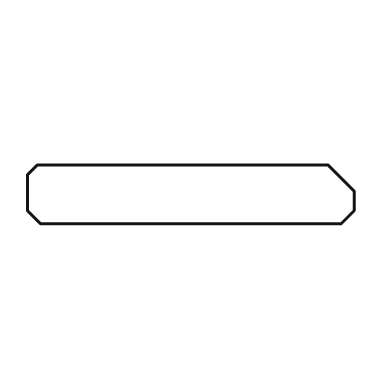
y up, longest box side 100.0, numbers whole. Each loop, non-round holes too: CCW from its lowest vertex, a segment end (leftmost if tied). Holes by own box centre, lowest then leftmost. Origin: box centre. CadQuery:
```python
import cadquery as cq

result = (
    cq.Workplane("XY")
    .moveTo(-46.0, -9.0)
    .lineTo(46.0, -9.0)
    .lineTo(50.0, -5.0)
    .lineTo(50.0, 1.0)
    .lineTo(42.0, 9.0)
    .lineTo(-47.0, 9.0)
    .lineTo(-50.0, 6.0)
    .lineTo(-50.0, -5.0)
    .close()
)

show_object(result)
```